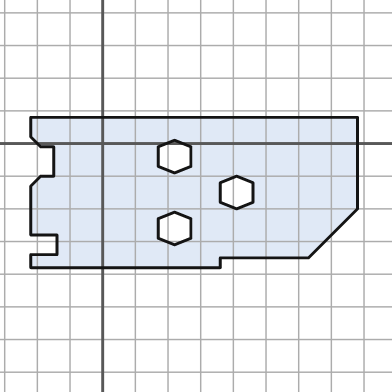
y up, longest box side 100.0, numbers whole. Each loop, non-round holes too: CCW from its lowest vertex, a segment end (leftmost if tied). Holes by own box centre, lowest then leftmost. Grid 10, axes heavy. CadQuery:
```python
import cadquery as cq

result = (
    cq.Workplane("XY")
    .moveTo(-22.0, -38.0)
    .lineTo(36.0, -38.0)
    .lineTo(36.0, -35.0)
    .lineTo(63.0, -35.0)
    .lineTo(78.0, -20.0)
    .lineTo(78.0, 8.0)
    .lineTo(-22.0, 8.0)
    .lineTo(-22.0, 2.0)
    .lineTo(-19.0, -1.0)
    .lineTo(-15.0, -1.0)
    .lineTo(-15.0, -10.0)
    .lineTo(-19.0, -10.0)
    .lineTo(-22.0, -13.0)
    .lineTo(-22.0, -28.0)
    .lineTo(-14.0, -28.0)
    .lineTo(-14.0, -34.0)
    .lineTo(-22.0, -34.0)
    .close()
    .moveTo(22.0, -31.0)
    .lineTo(27.0, -29.0)
    .lineTo(27.0, -23.0)
    .lineTo(22.0, -21.0)
    .lineTo(17.0, -23.0)
    .lineTo(17.0, -29.0)
    .close()
    .moveTo(41.0, -20.0)
    .lineTo(46.0, -18.0)
    .lineTo(46.0, -12.0)
    .lineTo(41.0, -10.0)
    .lineTo(36.0, -12.0)
    .lineTo(36.0, -18.0)
    .close()
    .moveTo(22.0, -9.0)
    .lineTo(27.0, -7.0)
    .lineTo(27.0, -1.0)
    .lineTo(22.0, 1.0)
    .lineTo(17.0, -1.0)
    .lineTo(17.0, -7.0)
    .close()
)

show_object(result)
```